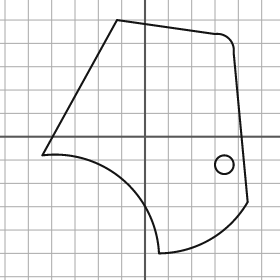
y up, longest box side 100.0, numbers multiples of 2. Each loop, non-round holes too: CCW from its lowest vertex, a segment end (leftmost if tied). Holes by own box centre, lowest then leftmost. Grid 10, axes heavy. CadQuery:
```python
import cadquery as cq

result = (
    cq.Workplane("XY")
    .moveTo(6.0, -50.0)
    .threePointArc((28.0, -44.0), (44.0, -28.0))
    .lineTo(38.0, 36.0)
    .threePointArc((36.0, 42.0), (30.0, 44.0))
    .lineTo(-12.0, 50.0)
    .lineTo(-44.0, -8.0)
    .threePointArc((-10.0, -18.0), (6.0, -50.0))
    .close()
    .moveTo(34.0, -12.0)
    .circle(4.0)
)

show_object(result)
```